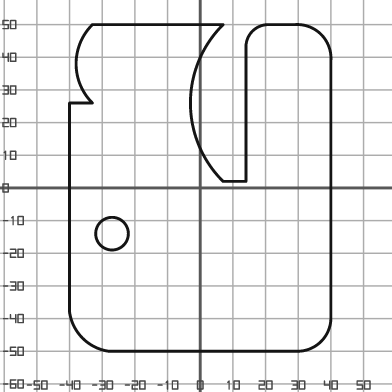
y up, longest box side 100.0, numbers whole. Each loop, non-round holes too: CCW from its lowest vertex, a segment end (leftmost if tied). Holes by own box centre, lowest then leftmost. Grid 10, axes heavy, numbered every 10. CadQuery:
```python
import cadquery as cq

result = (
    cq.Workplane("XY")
    .moveTo(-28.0, -50.0)
    .lineTo(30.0, -50.0)
    .threePointArc((37.0, -47.0), (40.0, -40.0))
    .lineTo(40.0, 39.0)
    .threePointArc((37.0, 47.0), (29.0, 50.0))
    .lineTo(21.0, 50.0)
    .threePointArc((16.0, 48.0), (14.0, 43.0))
    .lineTo(14.0, 2.0)
    .lineTo(7.0, 2.0)
    .threePointArc((-3.0, 26.0), (7.0, 50.0))
    .lineTo(-33.0, 50.0)
    .threePointArc((-38.0, 38.0), (-33.0, 26.0))
    .lineTo(-40.0, 26.0)
    .lineTo(-40.0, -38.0)
    .threePointArc((-36.0, -46.0), (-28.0, -50.0))
    .close()
    .moveTo(-27.0, -14.0)
    .circle(5.0)
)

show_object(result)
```